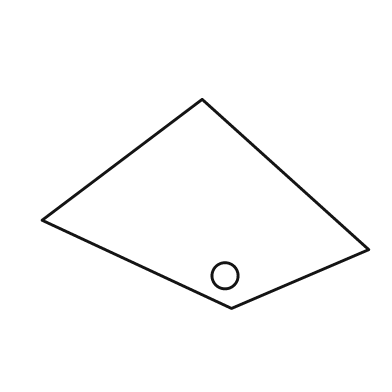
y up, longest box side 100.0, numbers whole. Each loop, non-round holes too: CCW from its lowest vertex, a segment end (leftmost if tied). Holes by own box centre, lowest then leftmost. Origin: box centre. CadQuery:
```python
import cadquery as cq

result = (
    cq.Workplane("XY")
    .moveTo(8.0, -32.0)
    .lineTo(50.0, -14.0)
    .lineTo(-1.0, 32.0)
    .lineTo(-50.0, -5.0)
    .close()
    .moveTo(6.0, -22.0)
    .circle(4.0)
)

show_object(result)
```